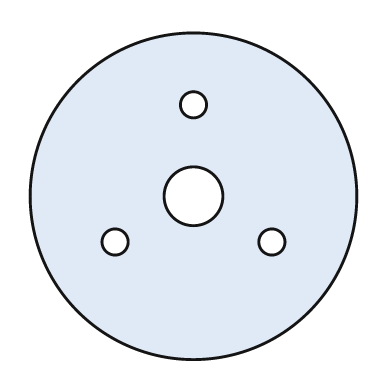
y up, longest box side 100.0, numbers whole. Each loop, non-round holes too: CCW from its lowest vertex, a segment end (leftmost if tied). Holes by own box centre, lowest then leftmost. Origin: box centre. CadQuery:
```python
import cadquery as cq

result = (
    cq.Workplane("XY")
    .moveTo(0.0, 0.0)
    .circle(50.0)
    .moveTo(-24.0, -14.0)
    .circle(4.0)
    .moveTo(24.0, -14.0)
    .circle(4.0)
    .moveTo(0.0, 0.0)
    .circle(9.0)
    .moveTo(0.0, 28.0)
    .circle(4.0)
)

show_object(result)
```